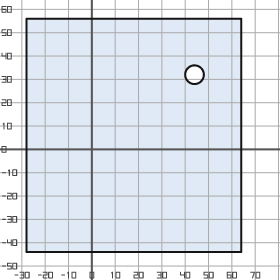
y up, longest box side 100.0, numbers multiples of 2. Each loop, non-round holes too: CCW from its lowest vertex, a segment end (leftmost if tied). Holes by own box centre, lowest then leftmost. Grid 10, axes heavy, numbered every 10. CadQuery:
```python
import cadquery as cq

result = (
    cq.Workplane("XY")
    .moveTo(-28.0, -44.0)
    .lineTo(64.0, -44.0)
    .lineTo(64.0, 56.0)
    .lineTo(-28.0, 56.0)
    .close()
    .moveTo(44.0, 32.0)
    .circle(4.0)
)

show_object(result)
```